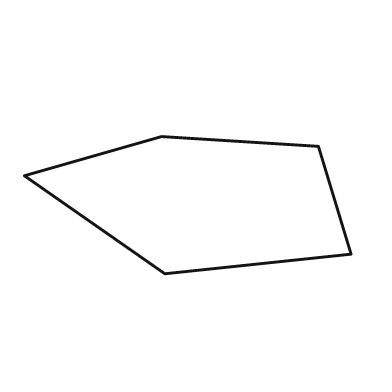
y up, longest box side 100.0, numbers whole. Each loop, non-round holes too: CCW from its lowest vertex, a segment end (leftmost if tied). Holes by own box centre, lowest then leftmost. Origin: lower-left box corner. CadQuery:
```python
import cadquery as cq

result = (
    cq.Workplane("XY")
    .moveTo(43.0, 0.0)
    .lineTo(100.0, 6.0)
    .lineTo(90.0, 39.0)
    .lineTo(42.0, 42.0)
    .lineTo(0.0, 30.0)
    .close()
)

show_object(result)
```